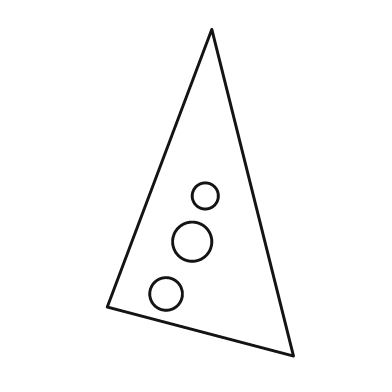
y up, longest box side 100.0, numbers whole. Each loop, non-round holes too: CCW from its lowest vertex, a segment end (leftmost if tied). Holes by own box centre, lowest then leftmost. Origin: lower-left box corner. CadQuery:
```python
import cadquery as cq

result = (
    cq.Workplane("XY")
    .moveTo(57.0, 0.0)
    .lineTo(32.0, 100.0)
    .lineTo(0.0, 15.0)
    .close()
    .moveTo(18.0, 19.0)
    .circle(5.0)
    .moveTo(26.0, 35.0)
    .circle(6.0)
    .moveTo(30.0, 49.0)
    .circle(4.0)
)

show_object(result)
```